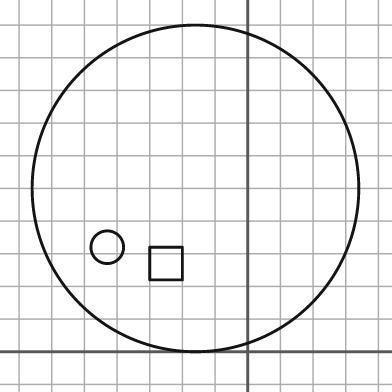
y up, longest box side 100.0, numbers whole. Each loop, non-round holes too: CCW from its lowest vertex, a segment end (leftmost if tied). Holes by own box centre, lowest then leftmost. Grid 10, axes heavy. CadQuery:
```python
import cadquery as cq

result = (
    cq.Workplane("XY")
    .moveTo(-16.0, 50.0)
    .circle(50.0)
    .moveTo(-30.0, 22.0)
    .lineTo(-20.0, 22.0)
    .lineTo(-20.0, 32.0)
    .lineTo(-30.0, 32.0)
    .close()
    .moveTo(-43.0, 32.0)
    .circle(5.0)
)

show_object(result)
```